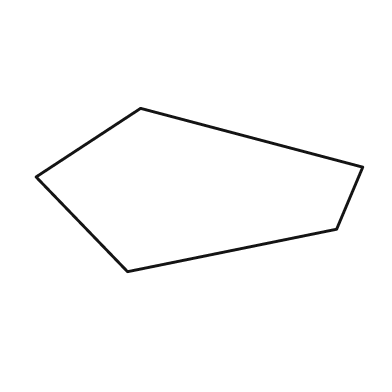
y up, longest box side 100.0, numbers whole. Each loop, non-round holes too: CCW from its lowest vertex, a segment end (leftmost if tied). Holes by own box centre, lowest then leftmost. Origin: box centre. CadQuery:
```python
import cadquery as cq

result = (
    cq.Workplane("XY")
    .moveTo(-22.0, -25.0)
    .lineTo(42.0, -12.0)
    .lineTo(50.0, 7.0)
    .lineTo(-18.0, 25.0)
    .lineTo(-50.0, 4.0)
    .close()
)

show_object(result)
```